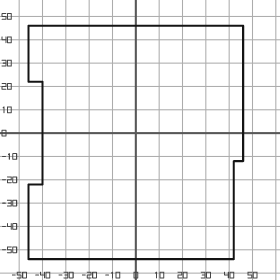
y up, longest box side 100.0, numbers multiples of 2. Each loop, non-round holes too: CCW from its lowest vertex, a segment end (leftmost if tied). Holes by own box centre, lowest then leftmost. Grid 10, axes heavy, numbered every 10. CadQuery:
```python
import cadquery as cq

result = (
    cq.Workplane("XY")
    .moveTo(-46.0, -54.0)
    .lineTo(42.0, -54.0)
    .lineTo(42.0, -12.0)
    .lineTo(46.0, -12.0)
    .lineTo(46.0, 46.0)
    .lineTo(-46.0, 46.0)
    .lineTo(-46.0, 22.0)
    .lineTo(-40.0, 22.0)
    .lineTo(-40.0, -22.0)
    .lineTo(-46.0, -22.0)
    .close()
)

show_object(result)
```